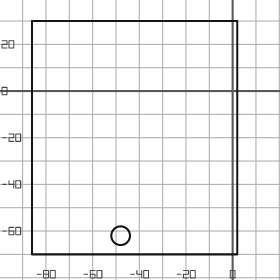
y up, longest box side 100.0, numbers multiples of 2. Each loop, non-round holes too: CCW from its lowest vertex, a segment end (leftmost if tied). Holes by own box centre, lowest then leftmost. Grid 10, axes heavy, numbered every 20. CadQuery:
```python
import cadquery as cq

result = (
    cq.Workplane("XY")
    .moveTo(-86.0, -70.0)
    .lineTo(2.0, -70.0)
    .lineTo(2.0, 30.0)
    .lineTo(-86.0, 30.0)
    .close()
    .moveTo(-48.0, -62.0)
    .circle(4.0)
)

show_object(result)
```